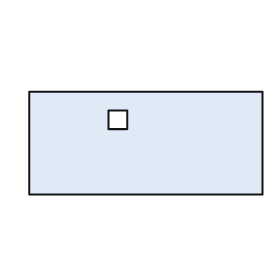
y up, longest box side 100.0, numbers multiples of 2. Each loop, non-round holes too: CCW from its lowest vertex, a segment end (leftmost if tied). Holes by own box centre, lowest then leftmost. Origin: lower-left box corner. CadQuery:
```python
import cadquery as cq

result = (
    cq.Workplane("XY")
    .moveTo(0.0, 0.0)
    .lineTo(100.0, 0.0)
    .lineTo(100.0, 44.0)
    .lineTo(0.0, 44.0)
    .close()
    .moveTo(34.0, 28.0)
    .lineTo(42.0, 28.0)
    .lineTo(42.0, 36.0)
    .lineTo(34.0, 36.0)
    .close()
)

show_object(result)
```